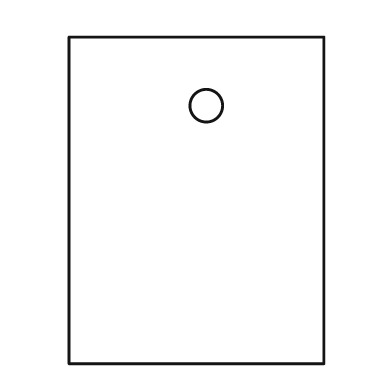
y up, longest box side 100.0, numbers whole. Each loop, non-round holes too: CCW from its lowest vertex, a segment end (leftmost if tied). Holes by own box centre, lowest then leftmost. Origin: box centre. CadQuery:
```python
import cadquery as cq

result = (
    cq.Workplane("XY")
    .moveTo(-39.0, -50.0)
    .lineTo(39.0, -50.0)
    .lineTo(39.0, 50.0)
    .lineTo(-39.0, 50.0)
    .close()
    .moveTo(3.0, 29.0)
    .circle(5.0)
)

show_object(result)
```